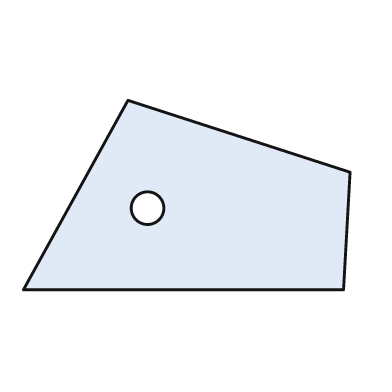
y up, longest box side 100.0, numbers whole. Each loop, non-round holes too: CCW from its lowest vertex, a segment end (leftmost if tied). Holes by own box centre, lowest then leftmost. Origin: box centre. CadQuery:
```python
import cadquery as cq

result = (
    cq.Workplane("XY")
    .moveTo(-50.0, -29.0)
    .lineTo(48.0, -29.0)
    .lineTo(50.0, 7.0)
    .lineTo(-18.0, 29.0)
    .close()
    .moveTo(-12.0, -4.0)
    .circle(5.0)
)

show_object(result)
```